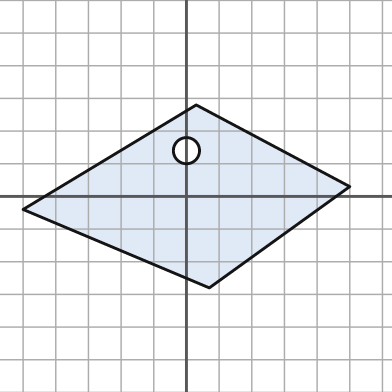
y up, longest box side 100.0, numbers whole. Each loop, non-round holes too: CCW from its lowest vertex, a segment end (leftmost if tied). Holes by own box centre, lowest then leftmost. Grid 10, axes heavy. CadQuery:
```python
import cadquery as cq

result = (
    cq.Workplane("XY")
    .moveTo(7.0, -28.0)
    .lineTo(50.0, 3.0)
    .lineTo(3.0, 28.0)
    .lineTo(-50.0, -4.0)
    .close()
    .moveTo(0.0, 14.0)
    .circle(4.0)
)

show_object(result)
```